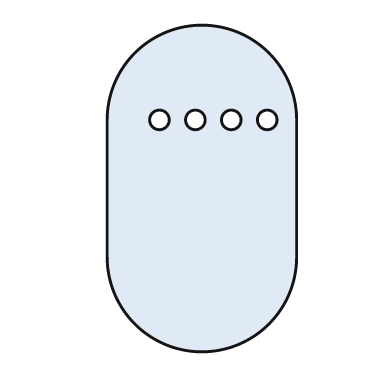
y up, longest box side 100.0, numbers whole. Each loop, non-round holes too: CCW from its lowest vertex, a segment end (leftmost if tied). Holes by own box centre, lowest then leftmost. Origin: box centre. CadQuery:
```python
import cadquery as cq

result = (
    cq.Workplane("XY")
    .moveTo(-29.0, -21.0)
    .threePointArc((0.0, -50.0), (29.0, -21.0))
    .lineTo(29.0, 21.0)
    .threePointArc((0.0, 50.0), (-29.0, 21.0))
    .close()
    .moveTo(-13.0, 21.0)
    .circle(3.0)
    .moveTo(-2.0, 21.0)
    .circle(3.0)
    .moveTo(9.0, 21.0)
    .circle(3.0)
    .moveTo(20.0, 21.0)
    .circle(3.0)
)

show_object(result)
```